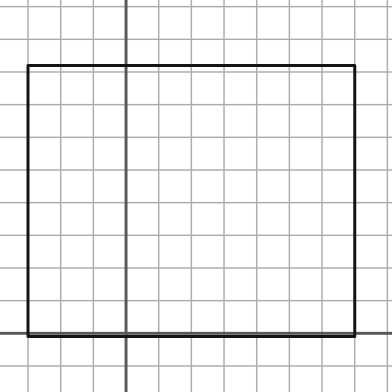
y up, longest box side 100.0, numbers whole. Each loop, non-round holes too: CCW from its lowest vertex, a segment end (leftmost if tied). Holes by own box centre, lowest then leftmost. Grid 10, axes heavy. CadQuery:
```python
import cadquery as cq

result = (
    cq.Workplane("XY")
    .moveTo(-30.0, -1.0)
    .lineTo(70.0, -1.0)
    .lineTo(70.0, 82.0)
    .lineTo(-30.0, 82.0)
    .close()
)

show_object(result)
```